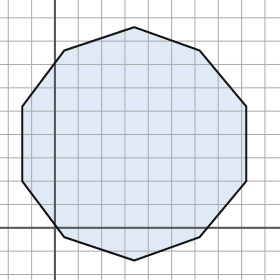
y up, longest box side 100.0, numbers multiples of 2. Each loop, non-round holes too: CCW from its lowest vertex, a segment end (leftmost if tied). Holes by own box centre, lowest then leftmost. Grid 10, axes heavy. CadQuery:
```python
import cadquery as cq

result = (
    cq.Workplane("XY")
    .moveTo(34.0, -14.0)
    .lineTo(62.0, -4.0)
    .lineTo(82.0, 20.0)
    .lineTo(82.0, 52.0)
    .lineTo(62.0, 76.0)
    .lineTo(34.0, 86.0)
    .lineTo(4.0, 76.0)
    .lineTo(-14.0, 52.0)
    .lineTo(-14.0, 20.0)
    .lineTo(4.0, -4.0)
    .close()
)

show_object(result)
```